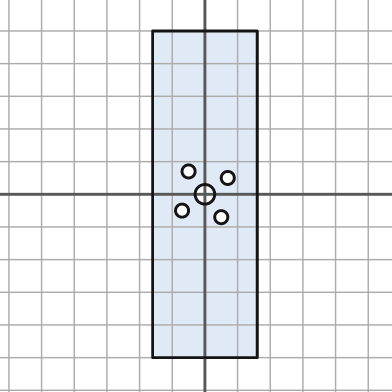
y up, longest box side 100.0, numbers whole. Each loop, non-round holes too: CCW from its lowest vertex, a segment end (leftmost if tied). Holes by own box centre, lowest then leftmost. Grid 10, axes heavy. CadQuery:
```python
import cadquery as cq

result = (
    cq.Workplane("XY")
    .moveTo(-16.0, -50.0)
    .lineTo(16.0, -50.0)
    .lineTo(16.0, 50.0)
    .lineTo(-16.0, 50.0)
    .close()
    .moveTo(5.0, -7.0)
    .circle(2.0)
    .moveTo(-7.0, -5.0)
    .circle(2.0)
    .moveTo(0.0, 0.0)
    .circle(3.0)
    .moveTo(7.0, 5.0)
    .circle(2.0)
    .moveTo(-5.0, 7.0)
    .circle(2.0)
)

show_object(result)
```